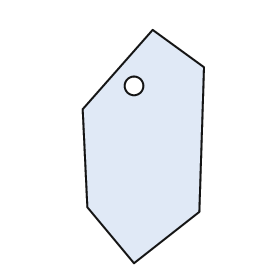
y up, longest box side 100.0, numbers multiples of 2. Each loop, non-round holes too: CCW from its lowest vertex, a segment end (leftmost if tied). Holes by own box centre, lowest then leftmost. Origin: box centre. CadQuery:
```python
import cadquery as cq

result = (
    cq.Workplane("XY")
    .moveTo(-4.0, -50.0)
    .lineTo(24.0, -28.0)
    .lineTo(26.0, 34.0)
    .lineTo(4.0, 50.0)
    .lineTo(-26.0, 16.0)
    .lineTo(-24.0, -26.0)
    .close()
    .moveTo(-4.0, 26.0)
    .circle(4.0)
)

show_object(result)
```